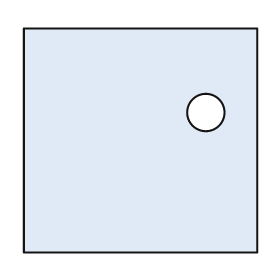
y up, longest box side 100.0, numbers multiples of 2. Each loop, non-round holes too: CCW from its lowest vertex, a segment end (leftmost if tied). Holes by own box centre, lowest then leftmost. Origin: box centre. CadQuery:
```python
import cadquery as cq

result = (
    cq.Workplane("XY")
    .moveTo(-50.0, -48.0)
    .lineTo(50.0, -48.0)
    .lineTo(50.0, 48.0)
    .lineTo(-50.0, 48.0)
    .close()
    .moveTo(28.0, 12.0)
    .circle(8.0)
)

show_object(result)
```